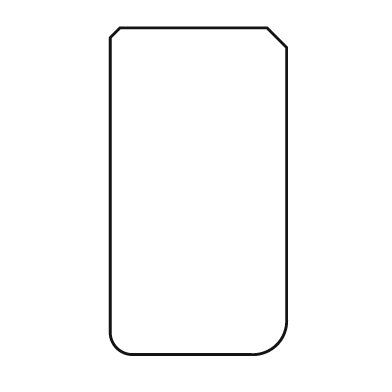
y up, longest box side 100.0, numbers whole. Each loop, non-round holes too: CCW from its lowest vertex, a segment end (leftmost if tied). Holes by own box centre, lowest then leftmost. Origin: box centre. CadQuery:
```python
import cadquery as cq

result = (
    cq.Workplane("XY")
    .moveTo(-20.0, -50.0)
    .lineTo(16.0, -50.0)
    .threePointArc((24.0, -47.0), (27.0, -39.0))
    .lineTo(27.0, 44.0)
    .lineTo(21.0, 50.0)
    .lineTo(-24.0, 50.0)
    .lineTo(-27.0, 47.0)
    .lineTo(-27.0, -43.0)
    .threePointArc((-25.0, -48.0), (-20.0, -50.0))
    .close()
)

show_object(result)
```